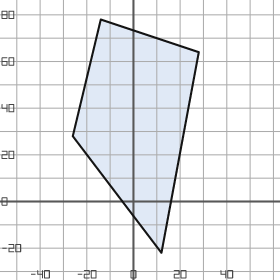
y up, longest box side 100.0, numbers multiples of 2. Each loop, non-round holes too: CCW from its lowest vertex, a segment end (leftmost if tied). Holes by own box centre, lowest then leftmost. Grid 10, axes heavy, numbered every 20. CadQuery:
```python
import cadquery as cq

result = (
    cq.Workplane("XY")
    .moveTo(12.0, -22.0)
    .lineTo(28.0, 64.0)
    .lineTo(-14.0, 78.0)
    .lineTo(-26.0, 28.0)
    .close()
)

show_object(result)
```